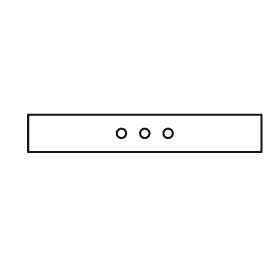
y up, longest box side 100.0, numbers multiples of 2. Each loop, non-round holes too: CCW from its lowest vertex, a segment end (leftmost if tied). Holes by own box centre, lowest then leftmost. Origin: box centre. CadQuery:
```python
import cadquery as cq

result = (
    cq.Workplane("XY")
    .moveTo(-50.0, -8.0)
    .lineTo(50.0, -8.0)
    .lineTo(50.0, 8.0)
    .lineTo(-50.0, 8.0)
    .close()
    .moveTo(-10.0, 0.0)
    .circle(2.0)
    .moveTo(0.0, 0.0)
    .circle(2.0)
    .moveTo(10.0, 0.0)
    .circle(2.0)
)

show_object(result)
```